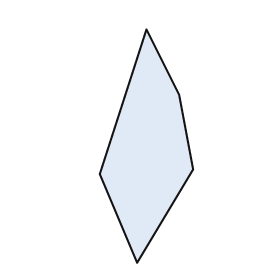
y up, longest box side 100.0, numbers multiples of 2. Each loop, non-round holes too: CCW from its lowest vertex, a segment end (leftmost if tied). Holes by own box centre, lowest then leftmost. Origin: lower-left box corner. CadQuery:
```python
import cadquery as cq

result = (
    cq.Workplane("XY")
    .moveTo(16.0, 0.0)
    .lineTo(40.0, 40.0)
    .lineTo(34.0, 72.0)
    .lineTo(20.0, 100.0)
    .lineTo(0.0, 38.0)
    .close()
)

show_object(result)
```